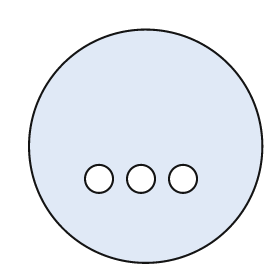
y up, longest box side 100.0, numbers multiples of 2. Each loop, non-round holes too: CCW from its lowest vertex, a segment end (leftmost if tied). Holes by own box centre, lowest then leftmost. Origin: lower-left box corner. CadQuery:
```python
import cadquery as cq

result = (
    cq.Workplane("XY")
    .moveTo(50.0, 50.0)
    .circle(50.0)
    .moveTo(30.0, 36.0)
    .circle(6.0)
    .moveTo(48.0, 36.0)
    .circle(6.0)
    .moveTo(66.0, 36.0)
    .circle(6.0)
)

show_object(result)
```